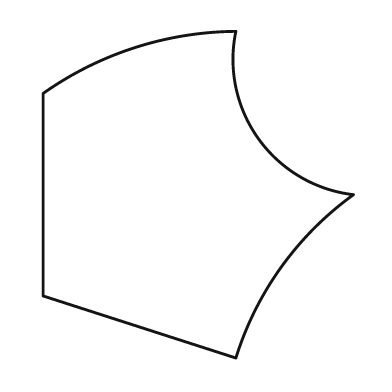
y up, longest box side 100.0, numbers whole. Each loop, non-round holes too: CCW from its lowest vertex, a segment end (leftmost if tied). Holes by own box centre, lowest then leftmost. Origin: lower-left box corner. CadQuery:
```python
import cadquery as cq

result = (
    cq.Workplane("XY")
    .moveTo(59.0, 0.0)
    .threePointArc((73.0, 28.0), (95.0, 50.0))
    .threePointArc((66.0, 67.0), (59.0, 100.0))
    .threePointArc((28.0, 95.0), (0.0, 81.0))
    .lineTo(0.0, 19.0)
    .close()
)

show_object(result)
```